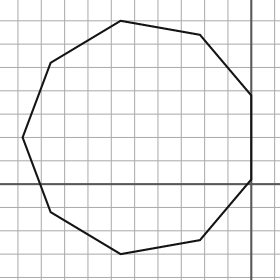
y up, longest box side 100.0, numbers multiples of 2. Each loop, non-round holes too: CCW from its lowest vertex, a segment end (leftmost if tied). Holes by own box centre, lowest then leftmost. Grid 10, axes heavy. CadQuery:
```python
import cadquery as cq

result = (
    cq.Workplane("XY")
    .moveTo(-56.0, -30.0)
    .lineTo(-22.0, -24.0)
    .lineTo(0.0, 2.0)
    .lineTo(0.0, 38.0)
    .lineTo(-22.0, 64.0)
    .lineTo(-56.0, 70.0)
    .lineTo(-86.0, 52.0)
    .lineTo(-98.0, 20.0)
    .lineTo(-86.0, -12.0)
    .close()
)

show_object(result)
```